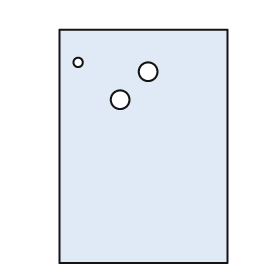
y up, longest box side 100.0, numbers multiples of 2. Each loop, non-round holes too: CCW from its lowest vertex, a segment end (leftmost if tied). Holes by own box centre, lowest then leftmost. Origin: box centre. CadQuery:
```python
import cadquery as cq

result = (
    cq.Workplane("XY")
    .moveTo(-36.0, -50.0)
    .lineTo(36.0, -50.0)
    .lineTo(36.0, 50.0)
    .lineTo(-36.0, 50.0)
    .close()
    .moveTo(-10.0, 20.0)
    .circle(4.0)
    .moveTo(2.0, 32.0)
    .circle(4.0)
    .moveTo(-28.0, 36.0)
    .circle(2.0)
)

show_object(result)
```